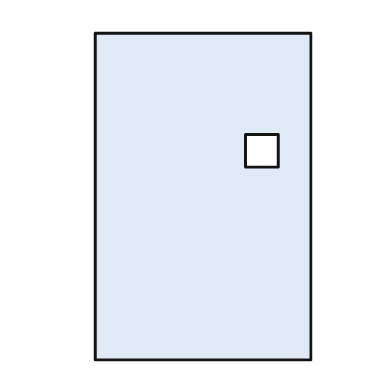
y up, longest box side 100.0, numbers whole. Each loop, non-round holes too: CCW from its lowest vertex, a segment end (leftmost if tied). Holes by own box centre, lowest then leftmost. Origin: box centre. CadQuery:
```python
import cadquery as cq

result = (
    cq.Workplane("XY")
    .moveTo(-33.0, -50.0)
    .lineTo(33.0, -50.0)
    .lineTo(33.0, 50.0)
    .lineTo(-33.0, 50.0)
    .close()
    .moveTo(13.0, 9.0)
    .lineTo(23.0, 9.0)
    .lineTo(23.0, 19.0)
    .lineTo(13.0, 19.0)
    .close()
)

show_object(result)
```